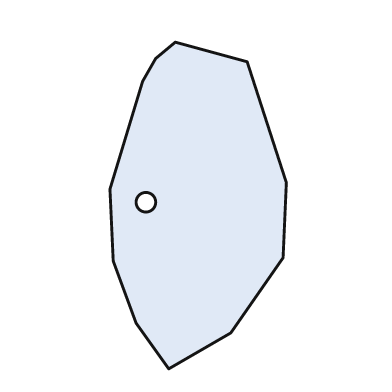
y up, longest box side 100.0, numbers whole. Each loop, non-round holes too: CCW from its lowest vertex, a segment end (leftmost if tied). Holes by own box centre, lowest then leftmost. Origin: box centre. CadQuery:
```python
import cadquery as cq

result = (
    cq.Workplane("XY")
    .moveTo(-9.0, -50.0)
    .lineTo(10.0, -39.0)
    .lineTo(26.0, -16.0)
    .lineTo(27.0, 7.0)
    .lineTo(15.0, 44.0)
    .lineTo(-7.0, 50.0)
    .lineTo(-13.0, 45.0)
    .lineTo(-17.0, 38.0)
    .lineTo(-27.0, 5.0)
    .lineTo(-26.0, -17.0)
    .lineTo(-19.0, -36.0)
    .close()
    .moveTo(-16.0, 1.0)
    .circle(3.0)
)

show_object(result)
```